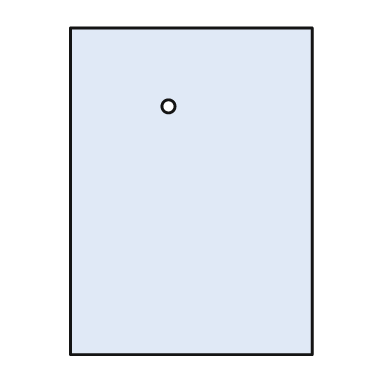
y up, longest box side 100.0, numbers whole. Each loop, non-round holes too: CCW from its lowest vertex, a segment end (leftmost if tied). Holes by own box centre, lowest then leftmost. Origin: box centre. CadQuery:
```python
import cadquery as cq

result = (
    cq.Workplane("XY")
    .moveTo(-37.0, -50.0)
    .lineTo(37.0, -50.0)
    .lineTo(37.0, 50.0)
    .lineTo(-37.0, 50.0)
    .close()
    .moveTo(-7.0, 26.0)
    .circle(2.0)
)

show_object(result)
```